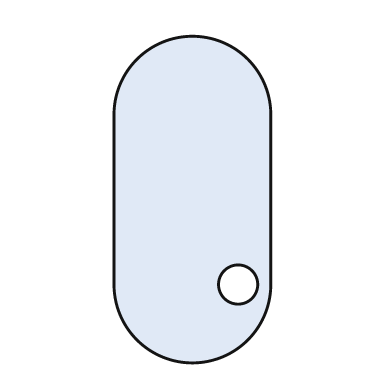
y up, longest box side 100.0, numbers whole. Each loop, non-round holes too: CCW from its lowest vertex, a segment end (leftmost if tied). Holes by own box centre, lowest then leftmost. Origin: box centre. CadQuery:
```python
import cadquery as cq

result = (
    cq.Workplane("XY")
    .moveTo(-24.0, -26.0)
    .threePointArc((0.0, -50.0), (24.0, -26.0))
    .lineTo(24.0, 26.0)
    .threePointArc((0.0, 50.0), (-24.0, 26.0))
    .close()
    .moveTo(14.0, -26.0)
    .circle(6.0)
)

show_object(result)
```